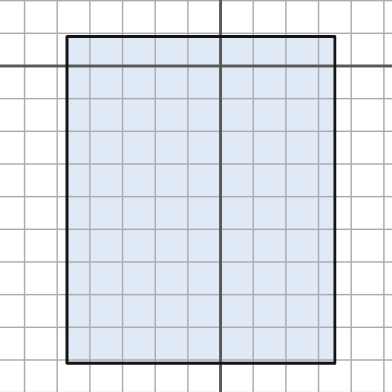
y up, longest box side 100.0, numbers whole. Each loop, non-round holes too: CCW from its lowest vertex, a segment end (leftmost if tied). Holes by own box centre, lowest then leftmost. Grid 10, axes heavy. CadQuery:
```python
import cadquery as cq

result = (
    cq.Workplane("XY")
    .moveTo(-47.0, -91.0)
    .lineTo(35.0, -91.0)
    .lineTo(35.0, 9.0)
    .lineTo(-47.0, 9.0)
    .close()
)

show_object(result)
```